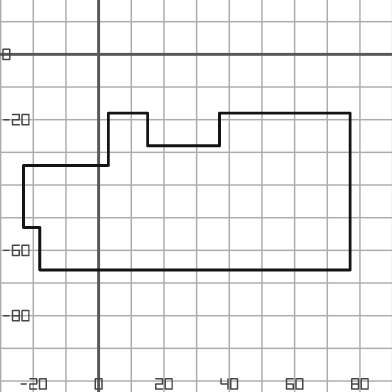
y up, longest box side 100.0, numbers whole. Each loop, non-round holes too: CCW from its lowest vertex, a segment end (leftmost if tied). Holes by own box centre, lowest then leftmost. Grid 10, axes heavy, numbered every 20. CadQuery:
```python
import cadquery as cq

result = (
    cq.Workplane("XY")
    .moveTo(-18.0, -66.0)
    .lineTo(77.0, -66.0)
    .lineTo(77.0, -18.0)
    .lineTo(37.0, -18.0)
    .lineTo(37.0, -28.0)
    .lineTo(15.0, -28.0)
    .lineTo(15.0, -18.0)
    .lineTo(3.0, -18.0)
    .lineTo(3.0, -34.0)
    .lineTo(-23.0, -34.0)
    .lineTo(-23.0, -53.0)
    .lineTo(-18.0, -53.0)
    .close()
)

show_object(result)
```